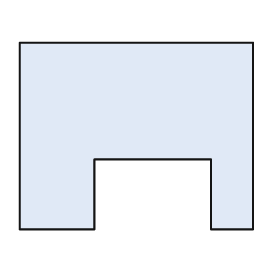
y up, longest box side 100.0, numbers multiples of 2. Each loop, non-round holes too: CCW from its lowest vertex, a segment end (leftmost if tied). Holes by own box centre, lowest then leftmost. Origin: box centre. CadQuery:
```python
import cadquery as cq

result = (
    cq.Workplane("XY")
    .moveTo(-50.0, -40.0)
    .lineTo(-18.0, -40.0)
    .lineTo(-18.0, -10.0)
    .lineTo(32.0, -10.0)
    .lineTo(32.0, -40.0)
    .lineTo(50.0, -40.0)
    .lineTo(50.0, 40.0)
    .lineTo(-50.0, 40.0)
    .close()
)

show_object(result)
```